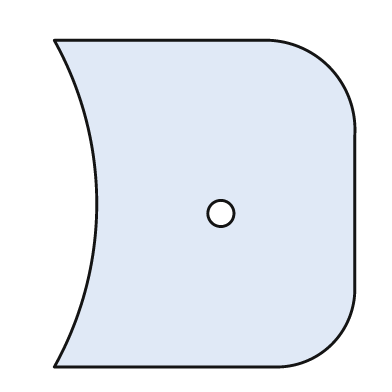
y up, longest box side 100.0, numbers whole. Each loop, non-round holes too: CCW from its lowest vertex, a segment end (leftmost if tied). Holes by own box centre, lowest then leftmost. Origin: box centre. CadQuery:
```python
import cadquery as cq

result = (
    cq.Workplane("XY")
    .moveTo(-46.0, -50.0)
    .lineTo(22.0, -50.0)
    .threePointArc((39.0, -43.0), (46.0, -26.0))
    .lineTo(46.0, 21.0)
    .threePointArc((38.0, 42.0), (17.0, 50.0))
    .lineTo(-46.0, 50.0)
    .threePointArc((-33.0, 0.0), (-46.0, -50.0))
    .close()
    .moveTo(5.0, -3.0)
    .circle(4.0)
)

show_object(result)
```